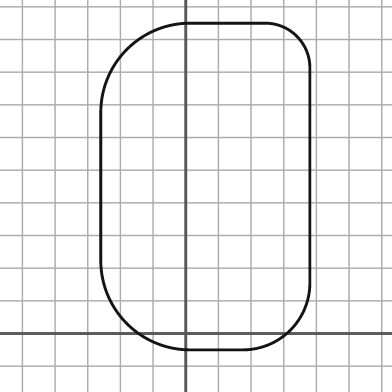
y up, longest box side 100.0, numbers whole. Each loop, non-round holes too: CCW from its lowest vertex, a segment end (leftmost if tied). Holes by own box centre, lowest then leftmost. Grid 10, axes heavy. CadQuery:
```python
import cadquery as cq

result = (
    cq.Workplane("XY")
    .moveTo(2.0, -5.0)
    .lineTo(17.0, -5.0)
    .threePointArc((32.0, 1.0), (38.0, 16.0))
    .lineTo(38.0, 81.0)
    .threePointArc((34.0, 91.0), (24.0, 95.0))
    .lineTo(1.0, 95.0)
    .threePointArc((-18.0, 87.0), (-26.0, 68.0))
    .lineTo(-26.0, 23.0)
    .threePointArc((-18.0, 3.0), (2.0, -5.0))
    .close()
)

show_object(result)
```